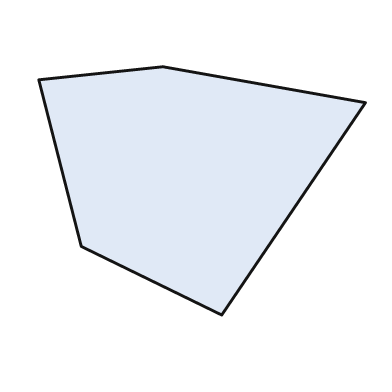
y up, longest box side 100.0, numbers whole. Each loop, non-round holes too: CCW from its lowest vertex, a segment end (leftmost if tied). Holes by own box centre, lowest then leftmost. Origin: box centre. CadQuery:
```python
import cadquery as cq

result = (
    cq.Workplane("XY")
    .moveTo(6.0, -38.0)
    .lineTo(50.0, 27.0)
    .lineTo(-12.0, 38.0)
    .lineTo(-50.0, 34.0)
    .lineTo(-37.0, -17.0)
    .close()
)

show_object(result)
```